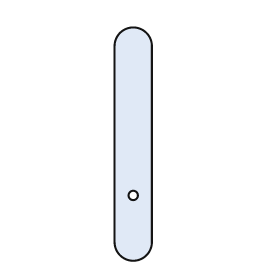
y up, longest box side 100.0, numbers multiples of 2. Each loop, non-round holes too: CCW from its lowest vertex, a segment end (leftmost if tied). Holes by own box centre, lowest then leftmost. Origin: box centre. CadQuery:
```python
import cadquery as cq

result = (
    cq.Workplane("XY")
    .moveTo(-8.0, -42.0)
    .threePointArc((0.0, -50.0), (8.0, -42.0))
    .lineTo(8.0, 42.0)
    .threePointArc((0.0, 50.0), (-8.0, 42.0))
    .close()
    .moveTo(0.0, -22.0)
    .circle(2.0)
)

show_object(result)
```